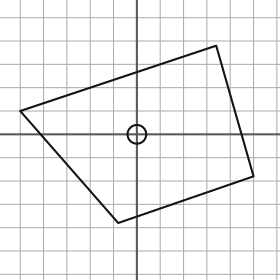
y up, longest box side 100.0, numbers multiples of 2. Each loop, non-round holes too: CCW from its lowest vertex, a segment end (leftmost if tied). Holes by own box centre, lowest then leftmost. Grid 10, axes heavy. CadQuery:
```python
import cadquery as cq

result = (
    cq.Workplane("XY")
    .moveTo(-8.0, -38.0)
    .lineTo(50.0, -18.0)
    .lineTo(34.0, 38.0)
    .lineTo(-50.0, 10.0)
    .close()
    .moveTo(0.0, 0.0)
    .circle(4.0)
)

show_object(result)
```